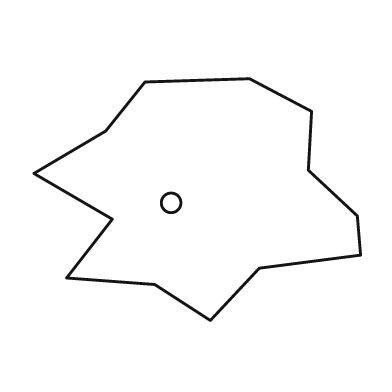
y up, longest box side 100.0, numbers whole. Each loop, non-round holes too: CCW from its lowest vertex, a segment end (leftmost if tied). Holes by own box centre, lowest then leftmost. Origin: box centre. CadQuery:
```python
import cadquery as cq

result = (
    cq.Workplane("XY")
    .moveTo(4.0, -37.0)
    .lineTo(19.0, -21.0)
    .lineTo(50.0, -17.0)
    .lineTo(49.0, -5.0)
    .lineTo(34.0, 9.0)
    .lineTo(35.0, 27.0)
    .lineTo(16.0, 37.0)
    .lineTo(-16.0, 36.0)
    .lineTo(-28.0, 21.0)
    .lineTo(-50.0, 8.0)
    .lineTo(-26.0, -6.0)
    .lineTo(-40.0, -24.0)
    .lineTo(-13.0, -26.0)
    .close()
    .moveTo(-8.0, -1.0)
    .circle(3.0)
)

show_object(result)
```